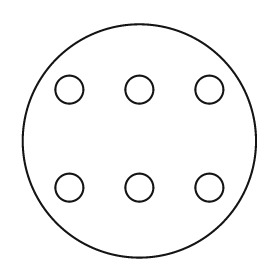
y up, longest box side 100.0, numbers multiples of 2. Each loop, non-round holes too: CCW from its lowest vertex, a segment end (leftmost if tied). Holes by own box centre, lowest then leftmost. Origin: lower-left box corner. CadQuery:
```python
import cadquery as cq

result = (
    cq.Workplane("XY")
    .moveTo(50.0, 50.0)
    .circle(50.0)
    .moveTo(20.0, 30.0)
    .circle(6.0)
    .moveTo(50.0, 30.0)
    .circle(6.0)
    .moveTo(80.0, 30.0)
    .circle(6.0)
    .moveTo(20.0, 72.0)
    .circle(6.0)
    .moveTo(50.0, 72.0)
    .circle(6.0)
    .moveTo(80.0, 72.0)
    .circle(6.0)
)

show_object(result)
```